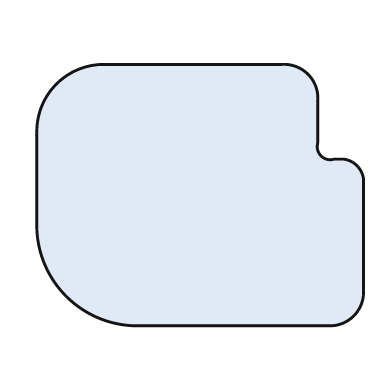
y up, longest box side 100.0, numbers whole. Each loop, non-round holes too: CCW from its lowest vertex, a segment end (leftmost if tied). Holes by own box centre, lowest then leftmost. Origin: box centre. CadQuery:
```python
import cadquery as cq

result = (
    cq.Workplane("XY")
    .moveTo(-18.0, -40.0)
    .lineTo(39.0, -40.0)
    .threePointArc((47.0, -37.0), (50.0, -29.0))
    .lineTo(50.0, 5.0)
    .threePointArc((48.0, 9.0), (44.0, 11.0))
    .lineTo(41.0, 11.0)
    .threePointArc((37.0, 12.0), (36.0, 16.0))
    .lineTo(36.0, 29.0)
    .threePointArc((33.0, 37.0), (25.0, 40.0))
    .lineTo(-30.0, 40.0)
    .threePointArc((-44.0, 34.0), (-50.0, 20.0))
    .lineTo(-50.0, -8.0)
    .threePointArc((-41.0, -31.0), (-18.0, -40.0))
    .close()
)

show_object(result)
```